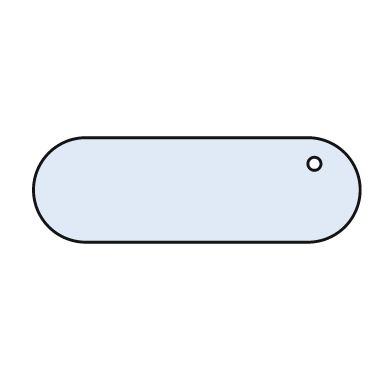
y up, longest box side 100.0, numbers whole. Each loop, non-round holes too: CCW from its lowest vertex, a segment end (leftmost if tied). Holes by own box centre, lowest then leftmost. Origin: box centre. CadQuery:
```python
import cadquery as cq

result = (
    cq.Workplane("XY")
    .moveTo(-34.0, -16.0)
    .lineTo(34.0, -16.0)
    .threePointArc((50.0, 0.0), (34.0, 16.0))
    .lineTo(-34.0, 16.0)
    .threePointArc((-50.0, 0.0), (-34.0, -16.0))
    .close()
    .moveTo(36.0, 8.0)
    .circle(2.0)
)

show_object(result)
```